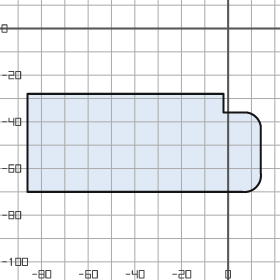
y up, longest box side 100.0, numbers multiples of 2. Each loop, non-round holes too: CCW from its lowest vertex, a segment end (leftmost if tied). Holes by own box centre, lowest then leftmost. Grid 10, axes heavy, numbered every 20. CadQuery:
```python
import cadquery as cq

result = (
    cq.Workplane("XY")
    .moveTo(-86.0, -70.0)
    .lineTo(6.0, -70.0)
    .threePointArc((12.0, -68.0), (14.0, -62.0))
    .lineTo(14.0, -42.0)
    .threePointArc((12.0, -38.0), (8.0, -36.0))
    .lineTo(-2.0, -36.0)
    .lineTo(-2.0, -28.0)
    .lineTo(-86.0, -28.0)
    .close()
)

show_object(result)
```